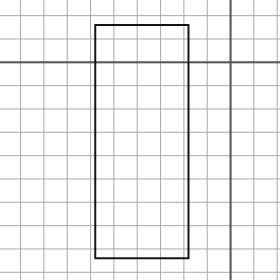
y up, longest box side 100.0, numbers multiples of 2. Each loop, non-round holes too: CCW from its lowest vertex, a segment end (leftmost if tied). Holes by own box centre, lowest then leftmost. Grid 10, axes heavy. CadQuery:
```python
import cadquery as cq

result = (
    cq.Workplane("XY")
    .moveTo(-58.0, -84.0)
    .lineTo(-18.0, -84.0)
    .lineTo(-18.0, 16.0)
    .lineTo(-58.0, 16.0)
    .close()
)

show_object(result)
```